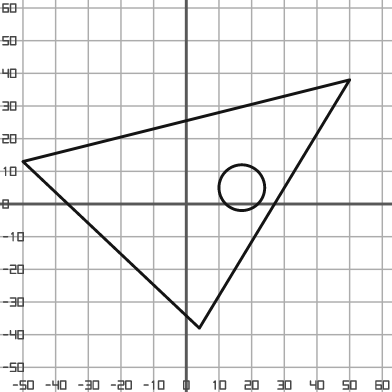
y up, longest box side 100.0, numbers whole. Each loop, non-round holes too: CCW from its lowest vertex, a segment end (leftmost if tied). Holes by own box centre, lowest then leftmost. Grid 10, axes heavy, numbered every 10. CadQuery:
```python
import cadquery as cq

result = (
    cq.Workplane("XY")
    .moveTo(4.0, -38.0)
    .lineTo(50.0, 38.0)
    .lineTo(-50.0, 13.0)
    .close()
    .moveTo(17.0, 5.0)
    .circle(7.0)
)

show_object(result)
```